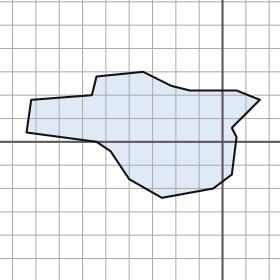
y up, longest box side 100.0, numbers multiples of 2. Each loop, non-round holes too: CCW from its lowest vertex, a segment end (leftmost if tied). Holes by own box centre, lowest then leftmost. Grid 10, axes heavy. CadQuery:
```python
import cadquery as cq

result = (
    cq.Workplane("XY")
    .moveTo(-26.0, -24.0)
    .lineTo(-4.0, -20.0)
    .lineTo(4.0, -14.0)
    .lineTo(6.0, 2.0)
    .lineTo(4.0, 6.0)
    .lineTo(16.0, 18.0)
    .lineTo(6.0, 22.0)
    .lineTo(-14.0, 22.0)
    .lineTo(-22.0, 24.0)
    .lineTo(-34.0, 30.0)
    .lineTo(-54.0, 28.0)
    .lineTo(-56.0, 20.0)
    .lineTo(-82.0, 18.0)
    .lineTo(-84.0, 4.0)
    .lineTo(-54.0, 0.0)
    .lineTo(-48.0, -4.0)
    .lineTo(-40.0, -16.0)
    .close()
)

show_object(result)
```